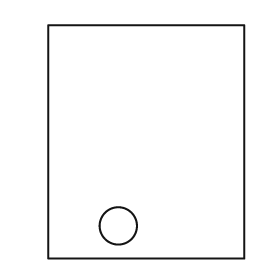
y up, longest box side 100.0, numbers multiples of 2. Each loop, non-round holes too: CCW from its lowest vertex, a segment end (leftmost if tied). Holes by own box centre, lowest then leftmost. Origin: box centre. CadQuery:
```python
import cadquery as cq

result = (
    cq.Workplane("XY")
    .moveTo(-42.0, -50.0)
    .lineTo(42.0, -50.0)
    .lineTo(42.0, 50.0)
    .lineTo(-42.0, 50.0)
    .close()
    .moveTo(-12.0, -36.0)
    .circle(8.0)
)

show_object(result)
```